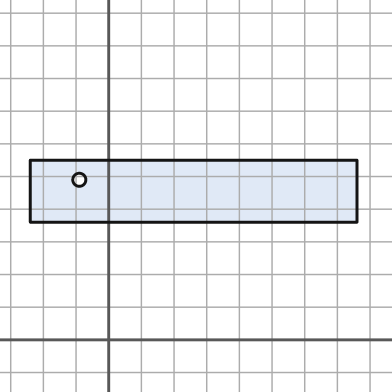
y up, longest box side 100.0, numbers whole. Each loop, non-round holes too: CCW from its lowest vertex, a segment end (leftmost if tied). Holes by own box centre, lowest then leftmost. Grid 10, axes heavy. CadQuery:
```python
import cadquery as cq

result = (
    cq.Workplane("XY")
    .moveTo(-24.0, 36.0)
    .lineTo(76.0, 36.0)
    .lineTo(76.0, 55.0)
    .lineTo(-24.0, 55.0)
    .close()
    .moveTo(-9.0, 49.0)
    .circle(2.0)
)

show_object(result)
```